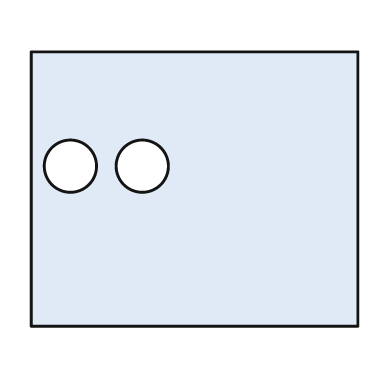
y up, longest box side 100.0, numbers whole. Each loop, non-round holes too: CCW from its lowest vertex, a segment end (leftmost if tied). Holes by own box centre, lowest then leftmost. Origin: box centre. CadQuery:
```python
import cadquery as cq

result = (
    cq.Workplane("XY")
    .moveTo(-50.0, -42.0)
    .lineTo(50.0, -42.0)
    .lineTo(50.0, 42.0)
    .lineTo(-50.0, 42.0)
    .close()
    .moveTo(-38.0, 7.0)
    .circle(8.0)
    .moveTo(-16.0, 7.0)
    .circle(8.0)
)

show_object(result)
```